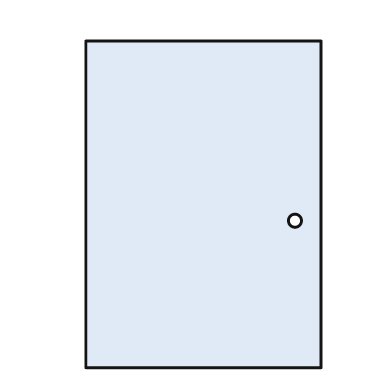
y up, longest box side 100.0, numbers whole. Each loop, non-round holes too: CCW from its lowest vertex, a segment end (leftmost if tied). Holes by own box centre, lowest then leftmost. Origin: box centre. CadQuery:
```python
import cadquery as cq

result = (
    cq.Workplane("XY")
    .moveTo(-36.0, -50.0)
    .lineTo(36.0, -50.0)
    .lineTo(36.0, 50.0)
    .lineTo(-36.0, 50.0)
    .close()
    .moveTo(28.0, -5.0)
    .circle(2.0)
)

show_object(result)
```